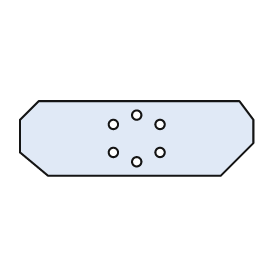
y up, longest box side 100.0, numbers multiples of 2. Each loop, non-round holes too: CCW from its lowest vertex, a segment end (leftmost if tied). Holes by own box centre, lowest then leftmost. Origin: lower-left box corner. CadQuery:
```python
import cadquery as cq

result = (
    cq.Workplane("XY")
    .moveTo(12.0, 0.0)
    .lineTo(86.0, 0.0)
    .lineTo(100.0, 14.0)
    .lineTo(100.0, 24.0)
    .lineTo(94.0, 32.0)
    .lineTo(8.0, 32.0)
    .lineTo(0.0, 24.0)
    .lineTo(0.0, 10.0)
    .close()
    .moveTo(50.0, 6.0)
    .circle(2.0)
    .moveTo(40.0, 10.0)
    .circle(2.0)
    .moveTo(60.0, 10.0)
    .circle(2.0)
    .moveTo(40.0, 22.0)
    .circle(2.0)
    .moveTo(60.0, 22.0)
    .circle(2.0)
    .moveTo(50.0, 26.0)
    .circle(2.0)
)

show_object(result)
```